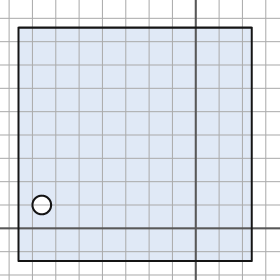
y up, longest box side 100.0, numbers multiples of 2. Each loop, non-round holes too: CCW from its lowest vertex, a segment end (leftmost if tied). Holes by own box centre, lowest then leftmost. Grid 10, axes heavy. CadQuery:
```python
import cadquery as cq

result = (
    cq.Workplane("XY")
    .moveTo(-76.0, -14.0)
    .lineTo(24.0, -14.0)
    .lineTo(24.0, 86.0)
    .lineTo(-76.0, 86.0)
    .close()
    .moveTo(-66.0, 10.0)
    .circle(4.0)
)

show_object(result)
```